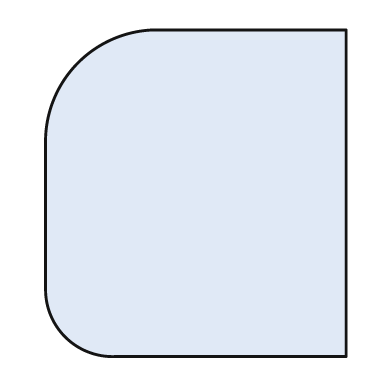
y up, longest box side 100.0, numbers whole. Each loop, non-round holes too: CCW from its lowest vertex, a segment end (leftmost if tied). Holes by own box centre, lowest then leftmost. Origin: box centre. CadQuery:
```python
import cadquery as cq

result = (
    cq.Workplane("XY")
    .moveTo(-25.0, -50.0)
    .lineTo(46.0, -50.0)
    .lineTo(46.0, 50.0)
    .lineTo(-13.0, 50.0)
    .threePointArc((-36.0, 40.0), (-46.0, 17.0))
    .lineTo(-46.0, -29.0)
    .threePointArc((-40.0, -44.0), (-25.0, -50.0))
    .close()
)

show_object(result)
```